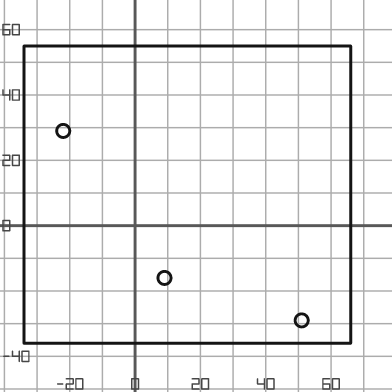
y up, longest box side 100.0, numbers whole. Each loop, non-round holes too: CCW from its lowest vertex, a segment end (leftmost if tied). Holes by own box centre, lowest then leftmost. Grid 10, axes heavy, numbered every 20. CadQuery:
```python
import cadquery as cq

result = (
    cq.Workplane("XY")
    .moveTo(-34.0, -36.0)
    .lineTo(66.0, -36.0)
    .lineTo(66.0, 55.0)
    .lineTo(-34.0, 55.0)
    .close()
    .moveTo(51.0, -29.0)
    .circle(2.0)
    .moveTo(9.0, -16.0)
    .circle(2.0)
    .moveTo(-22.0, 29.0)
    .circle(2.0)
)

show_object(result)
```